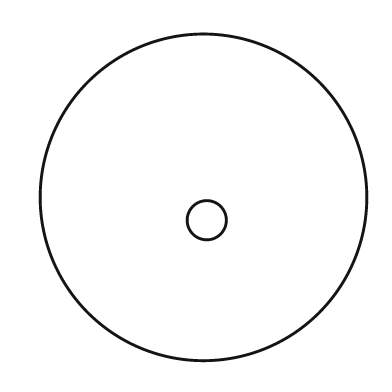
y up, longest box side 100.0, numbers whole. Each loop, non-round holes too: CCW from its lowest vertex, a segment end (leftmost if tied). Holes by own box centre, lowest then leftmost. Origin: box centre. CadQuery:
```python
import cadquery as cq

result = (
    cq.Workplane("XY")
    .moveTo(0.0, 0.0)
    .circle(50.0)
    .moveTo(1.0, -7.0)
    .circle(6.0)
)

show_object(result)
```